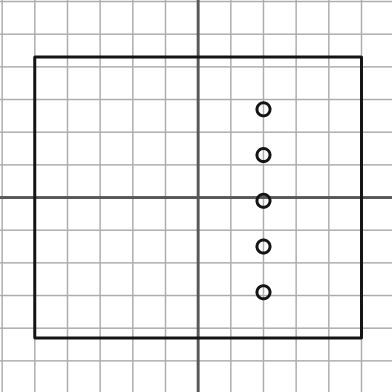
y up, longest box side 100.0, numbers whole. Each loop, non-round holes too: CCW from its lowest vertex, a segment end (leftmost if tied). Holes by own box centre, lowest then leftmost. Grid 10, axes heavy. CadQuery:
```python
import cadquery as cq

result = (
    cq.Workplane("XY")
    .moveTo(-50.0, -43.0)
    .lineTo(50.0, -43.0)
    .lineTo(50.0, 43.0)
    .lineTo(-50.0, 43.0)
    .close()
    .moveTo(20.0, -29.0)
    .circle(2.0)
    .moveTo(20.0, -15.0)
    .circle(2.0)
    .moveTo(20.0, -1.0)
    .circle(2.0)
    .moveTo(20.0, 13.0)
    .circle(2.0)
    .moveTo(20.0, 27.0)
    .circle(2.0)
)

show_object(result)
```